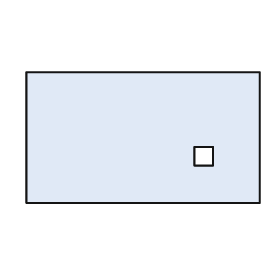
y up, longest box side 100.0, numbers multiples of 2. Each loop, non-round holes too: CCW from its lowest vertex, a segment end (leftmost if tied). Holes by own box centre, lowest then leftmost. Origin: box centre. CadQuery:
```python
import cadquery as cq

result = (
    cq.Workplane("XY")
    .moveTo(-50.0, -28.0)
    .lineTo(50.0, -28.0)
    .lineTo(50.0, 28.0)
    .lineTo(-50.0, 28.0)
    .close()
    .moveTo(22.0, -12.0)
    .lineTo(30.0, -12.0)
    .lineTo(30.0, -4.0)
    .lineTo(22.0, -4.0)
    .close()
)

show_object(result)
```